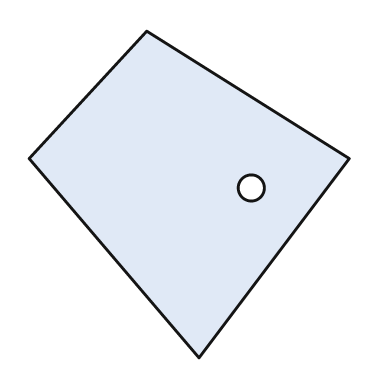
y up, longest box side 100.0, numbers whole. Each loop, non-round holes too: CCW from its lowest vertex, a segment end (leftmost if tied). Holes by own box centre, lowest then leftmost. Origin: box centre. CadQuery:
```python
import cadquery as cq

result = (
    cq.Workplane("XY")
    .moveTo(3.0, -50.0)
    .lineTo(49.0, 11.0)
    .lineTo(-13.0, 50.0)
    .lineTo(-49.0, 11.0)
    .close()
    .moveTo(19.0, 2.0)
    .circle(4.0)
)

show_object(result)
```